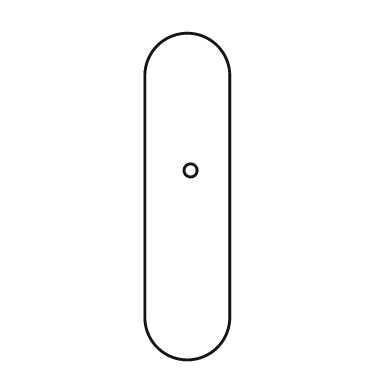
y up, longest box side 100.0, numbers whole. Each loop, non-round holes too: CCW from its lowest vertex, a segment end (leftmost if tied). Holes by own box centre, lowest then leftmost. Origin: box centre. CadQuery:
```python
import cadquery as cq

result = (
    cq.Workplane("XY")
    .moveTo(-13.0, -37.0)
    .threePointArc((0.0, -50.0), (13.0, -37.0))
    .lineTo(13.0, 37.0)
    .threePointArc((0.0, 50.0), (-13.0, 37.0))
    .close()
    .moveTo(1.0, 8.0)
    .circle(2.0)
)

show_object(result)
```